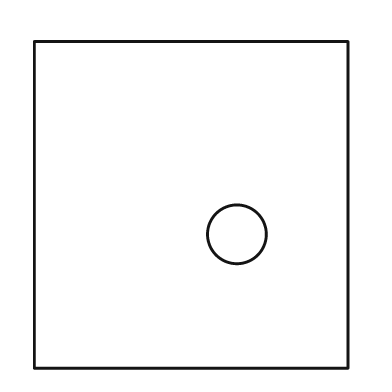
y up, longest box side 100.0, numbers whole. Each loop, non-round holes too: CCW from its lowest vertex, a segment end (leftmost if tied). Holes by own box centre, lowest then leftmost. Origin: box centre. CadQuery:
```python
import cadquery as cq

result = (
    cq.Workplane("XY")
    .moveTo(-48.0, -50.0)
    .lineTo(48.0, -50.0)
    .lineTo(48.0, 50.0)
    .lineTo(-48.0, 50.0)
    .close()
    .moveTo(14.0, -9.0)
    .circle(9.0)
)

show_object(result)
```